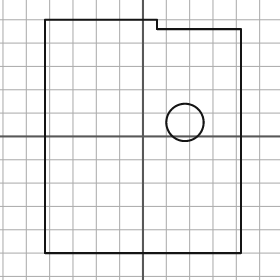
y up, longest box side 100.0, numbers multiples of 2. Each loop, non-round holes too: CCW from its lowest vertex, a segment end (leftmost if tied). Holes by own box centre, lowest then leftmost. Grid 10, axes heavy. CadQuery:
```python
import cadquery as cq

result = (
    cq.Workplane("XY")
    .moveTo(-42.0, -50.0)
    .lineTo(42.0, -50.0)
    .lineTo(42.0, 46.0)
    .lineTo(6.0, 46.0)
    .lineTo(6.0, 50.0)
    .lineTo(-42.0, 50.0)
    .close()
    .moveTo(18.0, 6.0)
    .circle(8.0)
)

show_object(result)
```